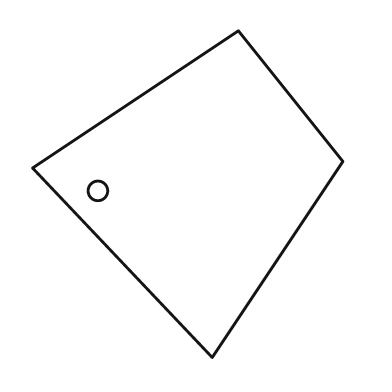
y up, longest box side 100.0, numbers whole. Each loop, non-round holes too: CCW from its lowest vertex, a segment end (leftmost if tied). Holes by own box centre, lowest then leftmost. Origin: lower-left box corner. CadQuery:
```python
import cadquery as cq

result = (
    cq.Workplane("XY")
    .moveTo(55.0, 0.0)
    .lineTo(95.0, 60.0)
    .lineTo(63.0, 100.0)
    .lineTo(0.0, 58.0)
    .close()
    .moveTo(20.0, 51.0)
    .circle(3.0)
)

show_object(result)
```